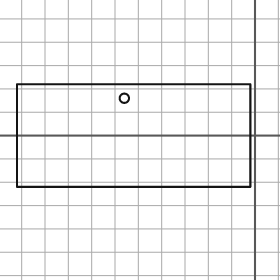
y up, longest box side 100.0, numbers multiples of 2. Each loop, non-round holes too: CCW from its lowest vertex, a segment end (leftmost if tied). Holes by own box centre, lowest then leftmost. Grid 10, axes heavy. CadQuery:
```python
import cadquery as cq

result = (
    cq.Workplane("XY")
    .moveTo(-102.0, -22.0)
    .lineTo(-2.0, -22.0)
    .lineTo(-2.0, 22.0)
    .lineTo(-102.0, 22.0)
    .close()
    .moveTo(-56.0, 16.0)
    .circle(2.0)
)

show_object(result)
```